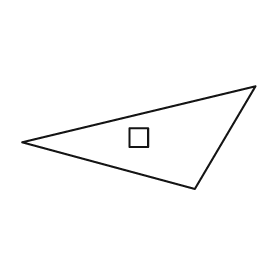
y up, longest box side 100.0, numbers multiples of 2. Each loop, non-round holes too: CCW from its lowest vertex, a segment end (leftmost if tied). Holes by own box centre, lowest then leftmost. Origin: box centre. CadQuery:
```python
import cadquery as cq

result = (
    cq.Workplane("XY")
    .moveTo(24.0, -22.0)
    .lineTo(50.0, 22.0)
    .lineTo(-50.0, -2.0)
    .close()
    .moveTo(-4.0, -4.0)
    .lineTo(4.0, -4.0)
    .lineTo(4.0, 4.0)
    .lineTo(-4.0, 4.0)
    .close()
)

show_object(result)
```